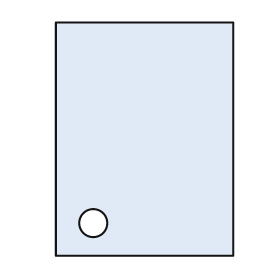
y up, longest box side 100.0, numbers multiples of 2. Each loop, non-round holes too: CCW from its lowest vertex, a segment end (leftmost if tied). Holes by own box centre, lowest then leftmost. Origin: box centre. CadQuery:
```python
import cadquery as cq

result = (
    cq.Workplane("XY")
    .moveTo(-38.0, -50.0)
    .lineTo(38.0, -50.0)
    .lineTo(38.0, 50.0)
    .lineTo(-38.0, 50.0)
    .close()
    .moveTo(-22.0, -36.0)
    .circle(6.0)
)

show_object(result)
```